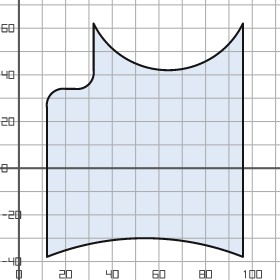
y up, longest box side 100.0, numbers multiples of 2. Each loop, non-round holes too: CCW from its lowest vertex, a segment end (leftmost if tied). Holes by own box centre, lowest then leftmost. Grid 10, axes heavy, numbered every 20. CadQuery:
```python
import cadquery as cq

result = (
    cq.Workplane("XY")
    .moveTo(12.0, -38.0)
    .threePointArc((54.0, -30.0), (96.0, -38.0))
    .lineTo(96.0, 62.0)
    .threePointArc((64.0, 42.0), (32.0, 62.0))
    .lineTo(32.0, 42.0)
    .threePointArc((30.0, 36.0), (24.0, 34.0))
    .lineTo(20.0, 34.0)
    .threePointArc((14.0, 32.0), (12.0, 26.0))
    .close()
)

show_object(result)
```